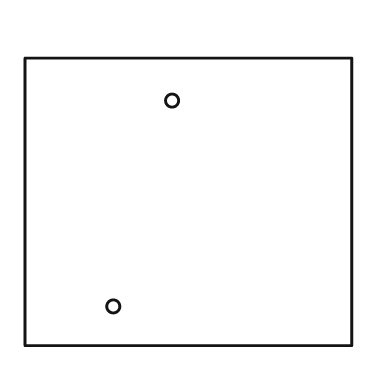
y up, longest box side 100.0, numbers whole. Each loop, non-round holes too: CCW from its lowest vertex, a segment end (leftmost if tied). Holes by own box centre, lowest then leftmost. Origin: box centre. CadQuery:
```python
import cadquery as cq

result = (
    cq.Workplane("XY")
    .moveTo(-50.0, -44.0)
    .lineTo(50.0, -44.0)
    .lineTo(50.0, 44.0)
    .lineTo(-50.0, 44.0)
    .close()
    .moveTo(-23.0, -32.0)
    .circle(2.0)
    .moveTo(-5.0, 31.0)
    .circle(2.0)
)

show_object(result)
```